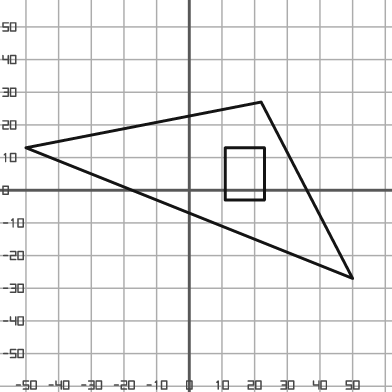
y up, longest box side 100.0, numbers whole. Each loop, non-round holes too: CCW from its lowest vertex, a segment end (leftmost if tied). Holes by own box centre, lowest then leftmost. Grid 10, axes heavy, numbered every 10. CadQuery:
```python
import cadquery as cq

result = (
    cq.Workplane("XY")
    .moveTo(50.0, -27.0)
    .lineTo(22.0, 27.0)
    .lineTo(-50.0, 13.0)
    .close()
    .moveTo(11.0, -3.0)
    .lineTo(23.0, -3.0)
    .lineTo(23.0, 13.0)
    .lineTo(11.0, 13.0)
    .close()
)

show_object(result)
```